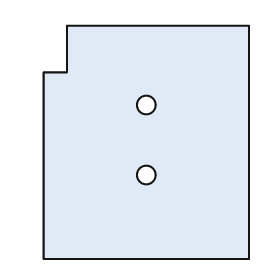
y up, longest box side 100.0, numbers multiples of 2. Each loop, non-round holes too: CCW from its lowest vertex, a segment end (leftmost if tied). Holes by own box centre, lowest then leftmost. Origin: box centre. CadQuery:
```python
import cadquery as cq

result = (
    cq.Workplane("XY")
    .moveTo(-44.0, -50.0)
    .lineTo(44.0, -50.0)
    .lineTo(44.0, 50.0)
    .lineTo(-34.0, 50.0)
    .lineTo(-34.0, 30.0)
    .lineTo(-44.0, 30.0)
    .close()
    .moveTo(0.0, -14.0)
    .circle(4.0)
    .moveTo(0.0, 16.0)
    .circle(4.0)
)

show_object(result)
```